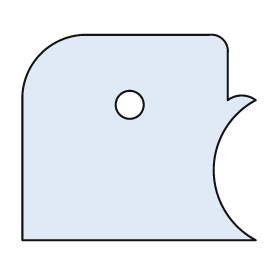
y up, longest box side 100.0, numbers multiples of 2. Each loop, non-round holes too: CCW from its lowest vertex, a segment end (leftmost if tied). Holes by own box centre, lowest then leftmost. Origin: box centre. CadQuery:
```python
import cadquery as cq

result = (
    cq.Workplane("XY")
    .moveTo(-50.0, -44.0)
    .lineTo(50.0, -44.0)
    .threePointArc((32.0, -14.0), (50.0, 16.0))
    .threePointArc((44.0, 18.0), (38.0, 16.0))
    .lineTo(38.0, 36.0)
    .threePointArc((36.0, 42.0), (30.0, 44.0))
    .lineTo(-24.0, 44.0)
    .threePointArc((-42.0, 36.0), (-50.0, 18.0))
    .close()
    .moveTo(-4.0, 14.0)
    .circle(6.0)
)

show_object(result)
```